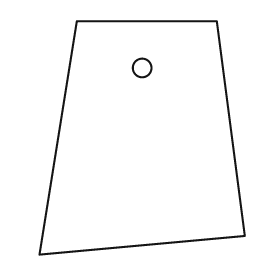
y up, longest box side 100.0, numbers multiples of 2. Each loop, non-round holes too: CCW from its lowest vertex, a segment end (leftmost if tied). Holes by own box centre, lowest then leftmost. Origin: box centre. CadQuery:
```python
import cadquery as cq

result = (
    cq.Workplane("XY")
    .moveTo(-44.0, -50.0)
    .lineTo(44.0, -42.0)
    .lineTo(32.0, 50.0)
    .lineTo(-28.0, 50.0)
    .close()
    .moveTo(0.0, 30.0)
    .circle(4.0)
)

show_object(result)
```